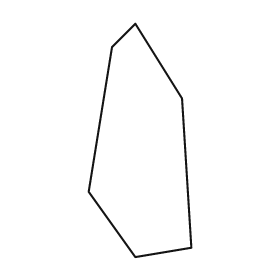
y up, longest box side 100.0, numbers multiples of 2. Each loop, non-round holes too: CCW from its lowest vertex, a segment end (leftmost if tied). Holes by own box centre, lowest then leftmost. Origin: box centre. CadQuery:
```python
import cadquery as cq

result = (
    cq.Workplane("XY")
    .moveTo(-2.0, -50.0)
    .lineTo(22.0, -46.0)
    .lineTo(18.0, 18.0)
    .lineTo(-2.0, 50.0)
    .lineTo(-12.0, 40.0)
    .lineTo(-22.0, -22.0)
    .close()
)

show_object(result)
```